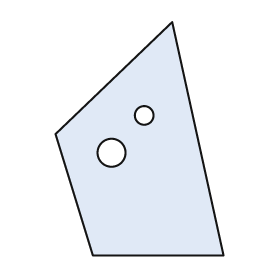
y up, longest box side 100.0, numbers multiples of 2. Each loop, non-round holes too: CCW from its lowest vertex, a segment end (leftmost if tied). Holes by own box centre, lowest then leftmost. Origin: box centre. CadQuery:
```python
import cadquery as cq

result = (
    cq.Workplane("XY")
    .moveTo(-20.0, -50.0)
    .lineTo(36.0, -50.0)
    .lineTo(14.0, 50.0)
    .lineTo(-36.0, 2.0)
    .close()
    .moveTo(-12.0, -6.0)
    .circle(6.0)
    .moveTo(2.0, 10.0)
    .circle(4.0)
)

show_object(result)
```